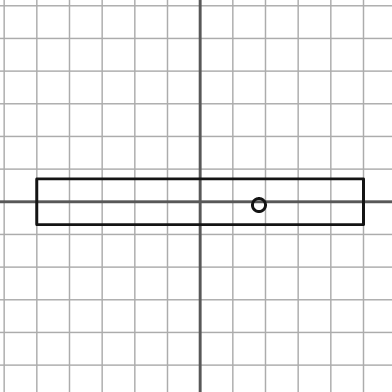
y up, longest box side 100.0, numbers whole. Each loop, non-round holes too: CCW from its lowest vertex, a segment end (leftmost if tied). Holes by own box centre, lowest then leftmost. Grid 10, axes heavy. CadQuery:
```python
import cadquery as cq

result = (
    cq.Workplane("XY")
    .moveTo(-50.0, -7.0)
    .lineTo(50.0, -7.0)
    .lineTo(50.0, 7.0)
    .lineTo(-50.0, 7.0)
    .close()
    .moveTo(18.0, -1.0)
    .circle(2.0)
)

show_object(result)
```